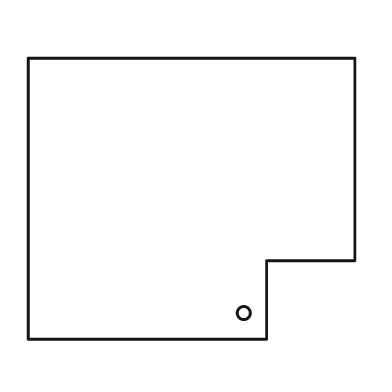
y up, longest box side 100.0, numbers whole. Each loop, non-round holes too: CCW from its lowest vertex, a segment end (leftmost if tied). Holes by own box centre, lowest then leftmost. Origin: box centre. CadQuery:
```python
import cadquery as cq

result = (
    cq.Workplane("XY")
    .moveTo(-50.0, -43.0)
    .lineTo(23.0, -43.0)
    .lineTo(23.0, -19.0)
    .lineTo(50.0, -19.0)
    .lineTo(50.0, 43.0)
    .lineTo(-50.0, 43.0)
    .close()
    .moveTo(16.0, -35.0)
    .circle(2.0)
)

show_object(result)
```